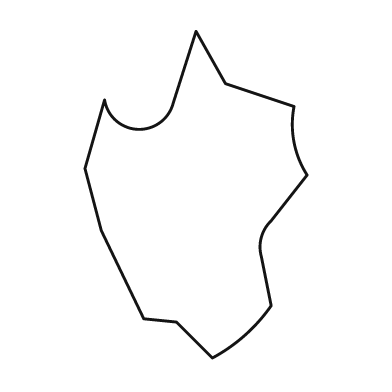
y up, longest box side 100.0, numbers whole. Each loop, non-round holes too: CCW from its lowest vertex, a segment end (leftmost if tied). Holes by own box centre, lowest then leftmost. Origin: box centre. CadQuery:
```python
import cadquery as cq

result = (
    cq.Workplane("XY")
    .moveTo(5.0, -50.0)
    .threePointArc((15.0, -43.0), (23.0, -34.0))
    .lineTo(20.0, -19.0)
    .threePointArc((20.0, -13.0), (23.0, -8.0))
    .lineTo(34.0, 6.0)
    .threePointArc((30.0, 16.0), (30.0, 27.0))
    .lineTo(9.0, 34.0)
    .lineTo(0.0, 50.0)
    .lineTo(-7.0, 28.0)
    .threePointArc((-18.0, 20.0), (-28.0, 29.0))
    .lineTo(-34.0, 8.0)
    .lineTo(-29.0, -11.0)
    .lineTo(-16.0, -38.0)
    .lineTo(-6.0, -39.0)
    .close()
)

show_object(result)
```